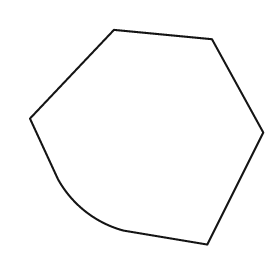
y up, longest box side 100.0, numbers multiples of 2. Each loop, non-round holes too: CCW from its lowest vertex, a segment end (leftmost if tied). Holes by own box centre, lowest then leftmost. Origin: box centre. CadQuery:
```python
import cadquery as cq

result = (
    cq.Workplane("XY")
    .moveTo(26.0, -46.0)
    .lineTo(50.0, 2.0)
    .lineTo(28.0, 42.0)
    .lineTo(-14.0, 46.0)
    .lineTo(-50.0, 8.0)
    .lineTo(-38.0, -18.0)
    .threePointArc((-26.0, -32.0), (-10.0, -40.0))
    .close()
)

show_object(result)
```